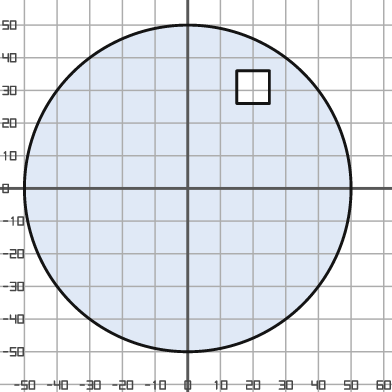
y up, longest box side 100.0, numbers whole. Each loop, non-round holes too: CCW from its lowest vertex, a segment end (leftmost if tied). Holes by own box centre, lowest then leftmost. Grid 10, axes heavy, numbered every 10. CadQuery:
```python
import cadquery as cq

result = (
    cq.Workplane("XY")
    .moveTo(0.0, 0.0)
    .circle(50.0)
    .moveTo(15.0, 26.0)
    .lineTo(25.0, 26.0)
    .lineTo(25.0, 36.0)
    .lineTo(15.0, 36.0)
    .close()
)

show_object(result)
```